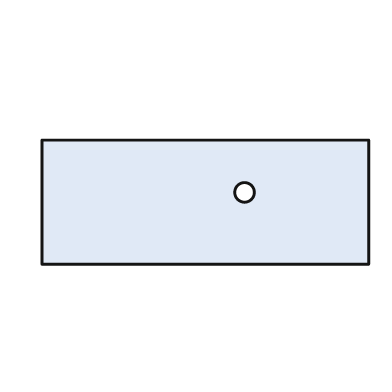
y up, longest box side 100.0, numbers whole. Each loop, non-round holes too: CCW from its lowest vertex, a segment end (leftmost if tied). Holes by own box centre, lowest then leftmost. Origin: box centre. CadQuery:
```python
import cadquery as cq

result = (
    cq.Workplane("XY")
    .moveTo(-50.0, -19.0)
    .lineTo(50.0, -19.0)
    .lineTo(50.0, 19.0)
    .lineTo(-50.0, 19.0)
    .close()
    .moveTo(12.0, 3.0)
    .circle(3.0)
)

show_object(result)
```